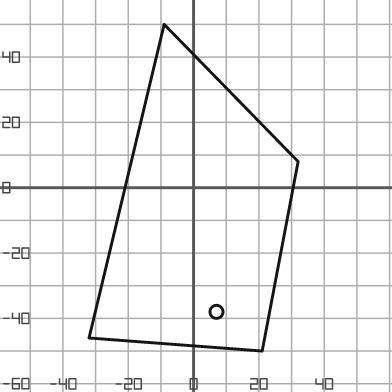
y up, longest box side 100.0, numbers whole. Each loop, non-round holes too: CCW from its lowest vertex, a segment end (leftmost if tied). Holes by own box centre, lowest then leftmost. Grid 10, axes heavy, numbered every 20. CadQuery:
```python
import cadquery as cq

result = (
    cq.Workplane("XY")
    .moveTo(21.0, -50.0)
    .lineTo(32.0, 8.0)
    .lineTo(-9.0, 50.0)
    .lineTo(-32.0, -46.0)
    .close()
    .moveTo(7.0, -38.0)
    .circle(2.0)
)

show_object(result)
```